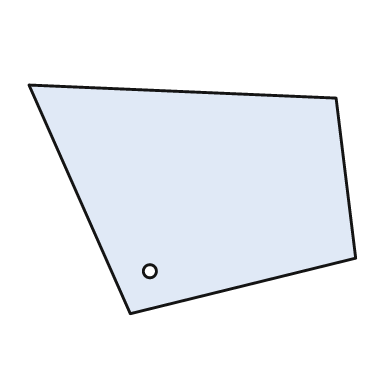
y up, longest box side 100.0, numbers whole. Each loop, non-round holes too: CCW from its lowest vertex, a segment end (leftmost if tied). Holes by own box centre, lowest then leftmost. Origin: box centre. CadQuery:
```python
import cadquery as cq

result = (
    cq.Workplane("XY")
    .moveTo(-19.0, -35.0)
    .lineTo(50.0, -18.0)
    .lineTo(44.0, 31.0)
    .lineTo(-50.0, 35.0)
    .close()
    .moveTo(-13.0, -22.0)
    .circle(2.0)
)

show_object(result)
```